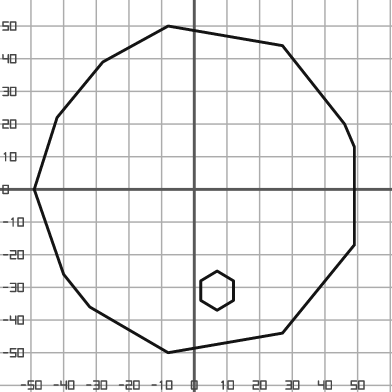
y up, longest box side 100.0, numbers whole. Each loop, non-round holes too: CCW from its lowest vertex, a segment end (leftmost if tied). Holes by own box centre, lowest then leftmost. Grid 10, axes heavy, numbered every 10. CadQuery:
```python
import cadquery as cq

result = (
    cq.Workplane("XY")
    .moveTo(-8.0, -50.0)
    .lineTo(27.0, -44.0)
    .lineTo(49.0, -17.0)
    .lineTo(49.0, 13.0)
    .lineTo(46.0, 20.0)
    .lineTo(27.0, 44.0)
    .lineTo(-8.0, 50.0)
    .lineTo(-28.0, 39.0)
    .lineTo(-42.0, 22.0)
    .lineTo(-49.0, 0.0)
    .lineTo(-40.0, -26.0)
    .lineTo(-32.0, -36.0)
    .close()
    .moveTo(7.0, -37.0)
    .lineTo(12.0, -34.0)
    .lineTo(12.0, -28.0)
    .lineTo(7.0, -25.0)
    .lineTo(2.0, -28.0)
    .lineTo(2.0, -34.0)
    .close()
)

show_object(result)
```